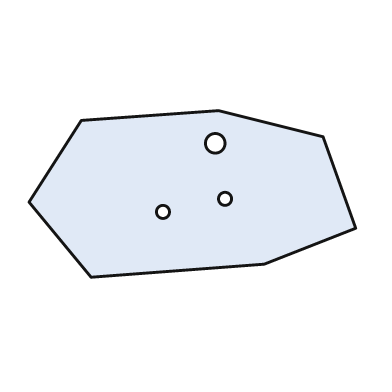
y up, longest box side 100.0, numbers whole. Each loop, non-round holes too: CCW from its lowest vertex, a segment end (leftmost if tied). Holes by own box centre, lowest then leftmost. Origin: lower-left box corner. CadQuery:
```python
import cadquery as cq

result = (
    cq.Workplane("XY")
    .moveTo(19.0, 0.0)
    .lineTo(72.0, 4.0)
    .lineTo(100.0, 15.0)
    .lineTo(90.0, 43.0)
    .lineTo(58.0, 51.0)
    .lineTo(16.0, 48.0)
    .lineTo(0.0, 23.0)
    .close()
    .moveTo(41.0, 20.0)
    .circle(2.0)
    .moveTo(60.0, 24.0)
    .circle(2.0)
    .moveTo(57.0, 41.0)
    .circle(3.0)
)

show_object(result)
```